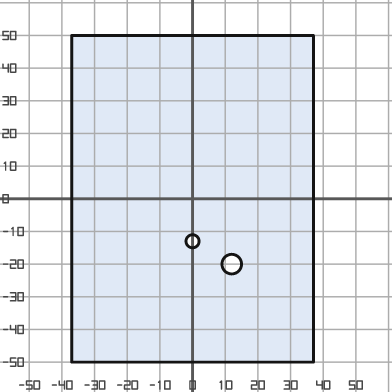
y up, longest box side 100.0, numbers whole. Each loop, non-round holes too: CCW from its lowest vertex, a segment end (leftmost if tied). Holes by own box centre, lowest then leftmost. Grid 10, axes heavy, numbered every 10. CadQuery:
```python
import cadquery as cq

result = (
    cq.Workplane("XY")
    .moveTo(-37.0, -50.0)
    .lineTo(37.0, -50.0)
    .lineTo(37.0, 50.0)
    .lineTo(-37.0, 50.0)
    .close()
    .moveTo(12.0, -20.0)
    .circle(3.0)
    .moveTo(0.0, -13.0)
    .circle(2.0)
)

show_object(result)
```